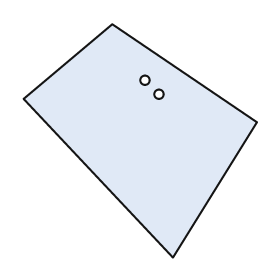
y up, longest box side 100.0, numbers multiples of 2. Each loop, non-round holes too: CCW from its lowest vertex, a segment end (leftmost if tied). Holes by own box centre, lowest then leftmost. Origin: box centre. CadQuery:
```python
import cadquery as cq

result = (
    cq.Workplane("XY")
    .moveTo(14.0, -50.0)
    .lineTo(50.0, 8.0)
    .lineTo(-12.0, 50.0)
    .lineTo(-50.0, 18.0)
    .close()
    .moveTo(8.0, 20.0)
    .circle(2.0)
    .moveTo(2.0, 26.0)
    .circle(2.0)
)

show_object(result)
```